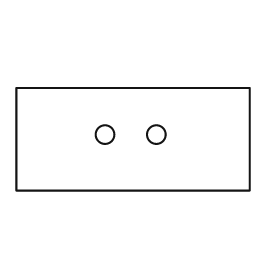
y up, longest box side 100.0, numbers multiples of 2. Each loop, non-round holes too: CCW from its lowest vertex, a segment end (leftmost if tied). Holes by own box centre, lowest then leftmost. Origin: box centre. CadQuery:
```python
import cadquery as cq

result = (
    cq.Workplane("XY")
    .moveTo(-50.0, -22.0)
    .lineTo(50.0, -22.0)
    .lineTo(50.0, 22.0)
    .lineTo(-50.0, 22.0)
    .close()
    .moveTo(-12.0, 2.0)
    .circle(4.0)
    .moveTo(10.0, 2.0)
    .circle(4.0)
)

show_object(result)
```